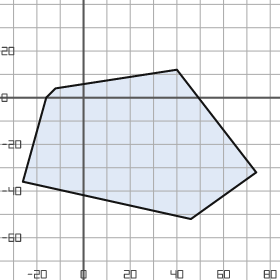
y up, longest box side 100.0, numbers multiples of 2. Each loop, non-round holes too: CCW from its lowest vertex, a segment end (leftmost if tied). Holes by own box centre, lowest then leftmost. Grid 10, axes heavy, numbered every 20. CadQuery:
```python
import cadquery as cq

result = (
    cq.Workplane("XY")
    .moveTo(46.0, -52.0)
    .lineTo(74.0, -32.0)
    .lineTo(40.0, 12.0)
    .lineTo(-12.0, 4.0)
    .lineTo(-16.0, 0.0)
    .lineTo(-26.0, -36.0)
    .close()
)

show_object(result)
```